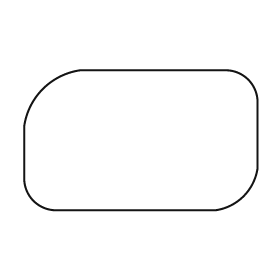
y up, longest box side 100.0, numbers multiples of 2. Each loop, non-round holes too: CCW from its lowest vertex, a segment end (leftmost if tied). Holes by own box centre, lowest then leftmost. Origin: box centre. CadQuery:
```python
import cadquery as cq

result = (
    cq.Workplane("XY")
    .moveTo(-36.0, -30.0)
    .lineTo(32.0, -30.0)
    .threePointArc((44.0, -24.0), (50.0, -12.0))
    .lineTo(50.0, 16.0)
    .threePointArc((46.0, 26.0), (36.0, 30.0))
    .lineTo(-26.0, 30.0)
    .threePointArc((-42.0, 22.0), (-50.0, 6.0))
    .lineTo(-50.0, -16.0)
    .threePointArc((-46.0, -26.0), (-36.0, -30.0))
    .close()
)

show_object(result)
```